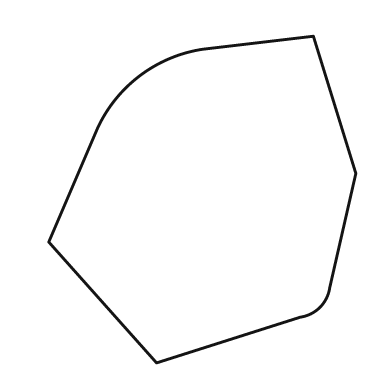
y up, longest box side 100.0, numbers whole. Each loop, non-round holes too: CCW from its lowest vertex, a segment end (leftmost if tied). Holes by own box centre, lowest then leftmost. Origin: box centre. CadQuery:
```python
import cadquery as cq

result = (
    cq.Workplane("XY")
    .moveTo(-14.0, -50.0)
    .lineTo(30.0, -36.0)
    .threePointArc((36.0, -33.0), (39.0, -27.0))
    .lineTo(47.0, 8.0)
    .lineTo(34.0, 50.0)
    .lineTo(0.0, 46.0)
    .threePointArc((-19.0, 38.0), (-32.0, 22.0))
    .lineTo(-47.0, -13.0)
    .close()
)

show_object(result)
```